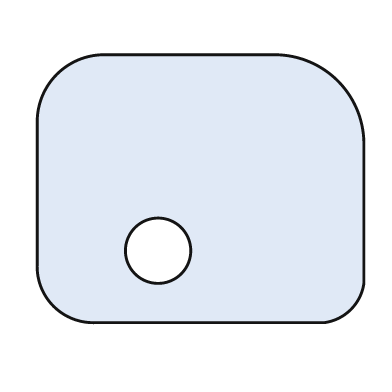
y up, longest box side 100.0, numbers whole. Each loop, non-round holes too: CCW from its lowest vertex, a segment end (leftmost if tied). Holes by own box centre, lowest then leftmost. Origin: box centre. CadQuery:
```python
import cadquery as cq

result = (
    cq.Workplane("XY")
    .moveTo(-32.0, -41.0)
    .lineTo(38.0, -41.0)
    .threePointArc((46.0, -37.0), (50.0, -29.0))
    .lineTo(50.0, 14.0)
    .threePointArc((42.0, 33.0), (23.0, 41.0))
    .lineTo(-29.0, 41.0)
    .threePointArc((-44.0, 35.0), (-50.0, 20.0))
    .lineTo(-50.0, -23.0)
    .threePointArc((-45.0, -36.0), (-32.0, -41.0))
    .close()
    .moveTo(-13.0, -19.0)
    .circle(10.0)
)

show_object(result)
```